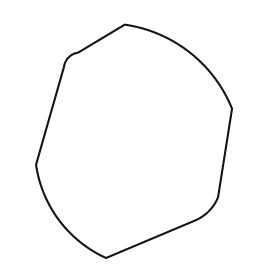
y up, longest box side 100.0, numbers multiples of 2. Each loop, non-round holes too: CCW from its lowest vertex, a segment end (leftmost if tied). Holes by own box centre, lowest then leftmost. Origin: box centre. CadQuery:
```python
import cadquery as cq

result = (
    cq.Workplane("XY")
    .moveTo(-12.0, -50.0)
    .lineTo(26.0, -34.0)
    .threePointArc((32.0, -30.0), (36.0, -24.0))
    .lineTo(42.0, 14.0)
    .threePointArc((24.0, 38.0), (-4.0, 50.0))
    .lineTo(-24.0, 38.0)
    .threePointArc((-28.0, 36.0), (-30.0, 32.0))
    .lineTo(-42.0, -10.0)
    .threePointArc((-32.0, -34.0), (-12.0, -50.0))
    .close()
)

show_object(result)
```